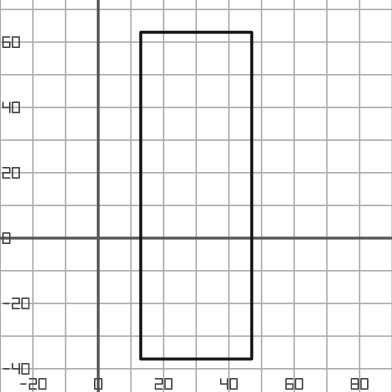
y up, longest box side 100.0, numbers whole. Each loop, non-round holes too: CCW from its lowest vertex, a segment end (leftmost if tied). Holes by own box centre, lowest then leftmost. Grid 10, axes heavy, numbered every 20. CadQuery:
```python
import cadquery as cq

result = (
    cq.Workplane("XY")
    .moveTo(13.0, -37.0)
    .lineTo(47.0, -37.0)
    .lineTo(47.0, 63.0)
    .lineTo(13.0, 63.0)
    .close()
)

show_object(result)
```